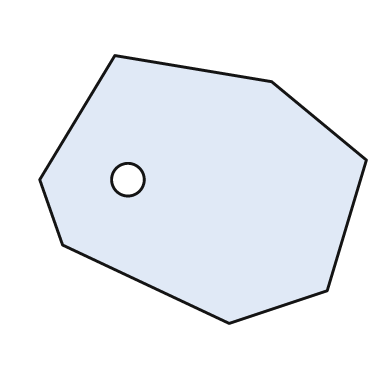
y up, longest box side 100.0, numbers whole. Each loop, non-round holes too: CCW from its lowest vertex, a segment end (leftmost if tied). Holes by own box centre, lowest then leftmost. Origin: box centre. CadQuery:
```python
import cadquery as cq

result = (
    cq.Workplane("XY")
    .moveTo(8.0, -41.0)
    .lineTo(38.0, -31.0)
    .lineTo(50.0, 9.0)
    .lineTo(21.0, 33.0)
    .lineTo(-27.0, 41.0)
    .lineTo(-50.0, 3.0)
    .lineTo(-43.0, -17.0)
    .close()
    .moveTo(-23.0, 3.0)
    .circle(5.0)
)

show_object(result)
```